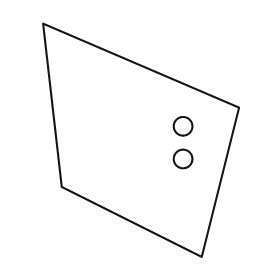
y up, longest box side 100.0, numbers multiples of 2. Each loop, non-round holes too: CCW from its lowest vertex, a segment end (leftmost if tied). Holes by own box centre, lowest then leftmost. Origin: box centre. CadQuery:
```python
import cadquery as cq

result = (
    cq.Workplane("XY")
    .moveTo(26.0, -50.0)
    .lineTo(42.0, 14.0)
    .lineTo(-42.0, 50.0)
    .lineTo(-34.0, -20.0)
    .close()
    .moveTo(18.0, -8.0)
    .circle(4.0)
    .moveTo(18.0, 6.0)
    .circle(4.0)
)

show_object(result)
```